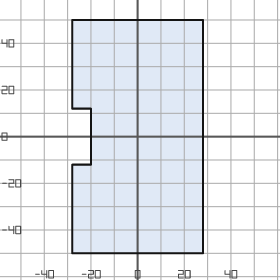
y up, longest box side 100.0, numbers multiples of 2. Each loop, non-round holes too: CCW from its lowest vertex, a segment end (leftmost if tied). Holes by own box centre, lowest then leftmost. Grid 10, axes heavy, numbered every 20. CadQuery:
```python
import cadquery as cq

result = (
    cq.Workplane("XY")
    .moveTo(-28.0, -50.0)
    .lineTo(28.0, -50.0)
    .lineTo(28.0, 50.0)
    .lineTo(-28.0, 50.0)
    .lineTo(-28.0, 12.0)
    .lineTo(-20.0, 12.0)
    .lineTo(-20.0, -12.0)
    .lineTo(-28.0, -12.0)
    .close()
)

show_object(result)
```